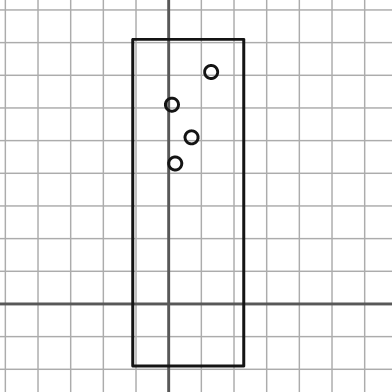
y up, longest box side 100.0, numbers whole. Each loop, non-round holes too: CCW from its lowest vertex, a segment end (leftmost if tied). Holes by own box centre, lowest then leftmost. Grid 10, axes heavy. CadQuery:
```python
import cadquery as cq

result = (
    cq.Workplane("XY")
    .moveTo(-11.0, -19.0)
    .lineTo(23.0, -19.0)
    .lineTo(23.0, 81.0)
    .lineTo(-11.0, 81.0)
    .close()
    .moveTo(2.0, 43.0)
    .circle(2.0)
    .moveTo(7.0, 51.0)
    .circle(2.0)
    .moveTo(1.0, 61.0)
    .circle(2.0)
    .moveTo(13.0, 71.0)
    .circle(2.0)
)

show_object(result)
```